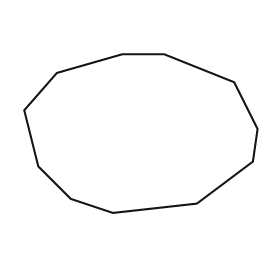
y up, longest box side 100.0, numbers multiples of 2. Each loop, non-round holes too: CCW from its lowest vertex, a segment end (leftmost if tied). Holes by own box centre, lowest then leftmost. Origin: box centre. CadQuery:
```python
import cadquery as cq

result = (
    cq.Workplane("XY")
    .moveTo(-12.0, -34.0)
    .lineTo(24.0, -30.0)
    .lineTo(48.0, -12.0)
    .lineTo(50.0, 2.0)
    .lineTo(40.0, 22.0)
    .lineTo(10.0, 34.0)
    .lineTo(-8.0, 34.0)
    .lineTo(-36.0, 26.0)
    .lineTo(-50.0, 10.0)
    .lineTo(-44.0, -14.0)
    .lineTo(-30.0, -28.0)
    .close()
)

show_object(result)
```